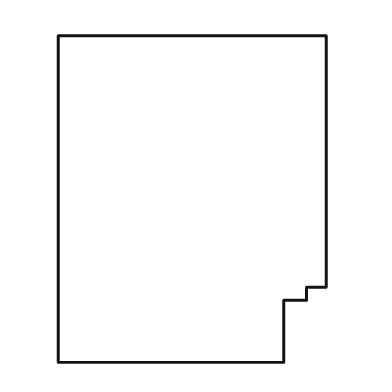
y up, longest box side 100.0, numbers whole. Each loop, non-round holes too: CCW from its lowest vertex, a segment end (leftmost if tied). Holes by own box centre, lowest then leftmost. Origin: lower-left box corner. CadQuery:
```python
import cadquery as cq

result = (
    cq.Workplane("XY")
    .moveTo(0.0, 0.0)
    .lineTo(69.0, 0.0)
    .lineTo(69.0, 19.0)
    .lineTo(76.0, 19.0)
    .lineTo(76.0, 23.0)
    .lineTo(82.0, 23.0)
    .lineTo(82.0, 100.0)
    .lineTo(0.0, 100.0)
    .close()
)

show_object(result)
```